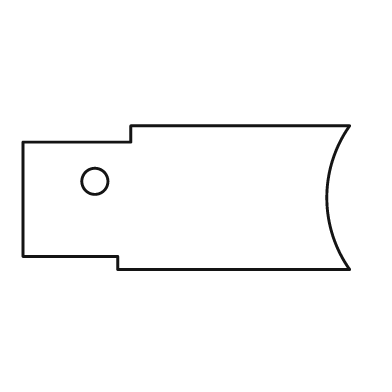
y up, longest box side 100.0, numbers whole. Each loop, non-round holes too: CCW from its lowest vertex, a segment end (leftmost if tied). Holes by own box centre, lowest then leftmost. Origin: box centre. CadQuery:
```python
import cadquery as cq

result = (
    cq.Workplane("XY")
    .moveTo(-21.0, -22.0)
    .lineTo(50.0, -22.0)
    .threePointArc((43.0, 0.0), (50.0, 22.0))
    .lineTo(-17.0, 22.0)
    .lineTo(-17.0, 17.0)
    .lineTo(-50.0, 17.0)
    .lineTo(-50.0, -18.0)
    .lineTo(-21.0, -18.0)
    .close()
    .moveTo(-28.0, 5.0)
    .circle(4.0)
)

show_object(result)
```